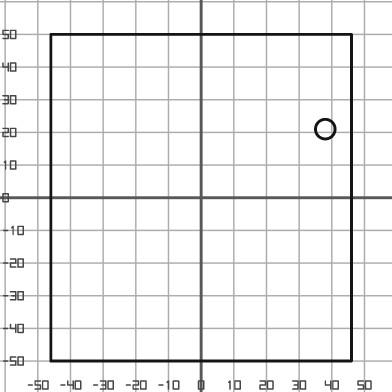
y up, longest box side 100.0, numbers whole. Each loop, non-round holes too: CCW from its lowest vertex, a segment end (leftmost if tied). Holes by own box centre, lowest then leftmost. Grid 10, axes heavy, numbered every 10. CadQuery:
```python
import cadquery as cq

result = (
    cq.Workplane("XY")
    .moveTo(-46.0, -50.0)
    .lineTo(46.0, -50.0)
    .lineTo(46.0, 50.0)
    .lineTo(-46.0, 50.0)
    .close()
    .moveTo(38.0, 21.0)
    .circle(3.0)
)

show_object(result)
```